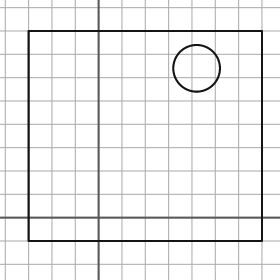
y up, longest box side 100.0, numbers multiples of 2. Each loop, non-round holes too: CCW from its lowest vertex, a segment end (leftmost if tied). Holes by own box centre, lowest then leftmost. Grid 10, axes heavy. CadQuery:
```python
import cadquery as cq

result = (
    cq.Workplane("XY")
    .moveTo(-30.0, -10.0)
    .lineTo(70.0, -10.0)
    .lineTo(70.0, 80.0)
    .lineTo(-30.0, 80.0)
    .close()
    .moveTo(42.0, 64.0)
    .circle(10.0)
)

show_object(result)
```